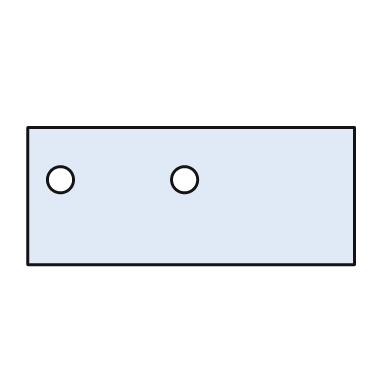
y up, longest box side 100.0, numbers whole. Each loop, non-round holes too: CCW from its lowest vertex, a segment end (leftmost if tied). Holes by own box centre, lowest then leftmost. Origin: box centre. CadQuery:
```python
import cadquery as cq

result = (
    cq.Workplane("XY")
    .moveTo(-50.0, -21.0)
    .lineTo(50.0, -21.0)
    .lineTo(50.0, 21.0)
    .lineTo(-50.0, 21.0)
    .close()
    .moveTo(-40.0, 5.0)
    .circle(4.0)
    .moveTo(-2.0, 5.0)
    .circle(4.0)
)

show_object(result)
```